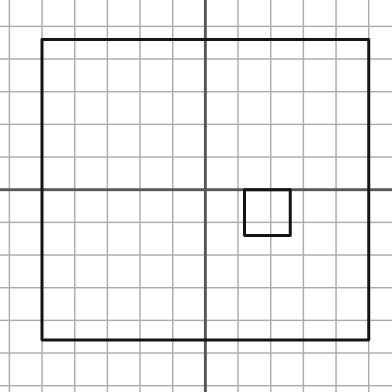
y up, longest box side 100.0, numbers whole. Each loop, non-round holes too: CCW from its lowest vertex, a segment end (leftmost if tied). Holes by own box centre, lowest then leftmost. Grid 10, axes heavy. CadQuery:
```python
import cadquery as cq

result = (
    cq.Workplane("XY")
    .moveTo(-50.0, -46.0)
    .lineTo(50.0, -46.0)
    .lineTo(50.0, 46.0)
    .lineTo(-50.0, 46.0)
    .close()
    .moveTo(12.0, -14.0)
    .lineTo(26.0, -14.0)
    .lineTo(26.0, 0.0)
    .lineTo(12.0, 0.0)
    .close()
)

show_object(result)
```